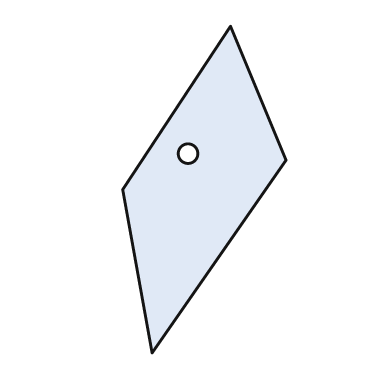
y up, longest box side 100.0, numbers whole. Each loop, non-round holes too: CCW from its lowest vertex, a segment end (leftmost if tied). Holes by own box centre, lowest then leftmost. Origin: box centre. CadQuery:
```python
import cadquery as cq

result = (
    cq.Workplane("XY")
    .moveTo(-16.0, -50.0)
    .lineTo(25.0, 9.0)
    .lineTo(8.0, 50.0)
    .lineTo(-25.0, 0.0)
    .close()
    .moveTo(-5.0, 11.0)
    .circle(3.0)
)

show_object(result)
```